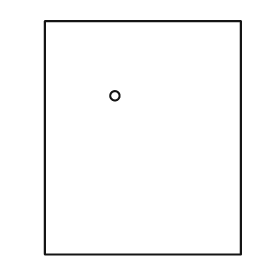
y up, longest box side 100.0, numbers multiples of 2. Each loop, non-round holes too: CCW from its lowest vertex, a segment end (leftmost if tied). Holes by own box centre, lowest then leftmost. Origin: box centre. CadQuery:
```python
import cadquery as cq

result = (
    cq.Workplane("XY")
    .moveTo(-42.0, -50.0)
    .lineTo(42.0, -50.0)
    .lineTo(42.0, 50.0)
    .lineTo(-42.0, 50.0)
    .close()
    .moveTo(-12.0, 18.0)
    .circle(2.0)
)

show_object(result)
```